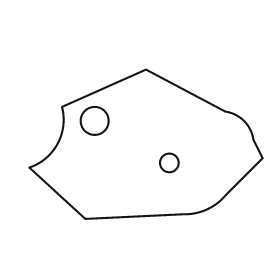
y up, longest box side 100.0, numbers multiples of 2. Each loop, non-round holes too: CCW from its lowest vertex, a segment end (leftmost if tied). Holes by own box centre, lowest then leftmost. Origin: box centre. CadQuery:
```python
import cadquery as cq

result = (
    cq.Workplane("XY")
    .moveTo(-26.0, -32.0)
    .lineTo(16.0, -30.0)
    .threePointArc((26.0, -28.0), (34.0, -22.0))
    .lineTo(50.0, -6.0)
    .lineTo(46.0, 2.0)
    .threePointArc((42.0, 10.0), (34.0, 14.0))
    .lineTo(0.0, 32.0)
    .lineTo(-36.0, 16.0)
    .threePointArc((-38.0, 0.0), (-50.0, -10.0))
    .close()
    .moveTo(10.0, -8.0)
    .circle(4.0)
    .moveTo(-22.0, 10.0)
    .circle(6.0)
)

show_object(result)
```